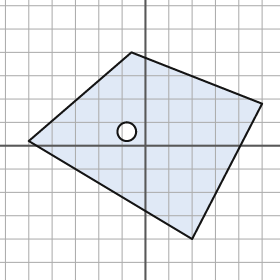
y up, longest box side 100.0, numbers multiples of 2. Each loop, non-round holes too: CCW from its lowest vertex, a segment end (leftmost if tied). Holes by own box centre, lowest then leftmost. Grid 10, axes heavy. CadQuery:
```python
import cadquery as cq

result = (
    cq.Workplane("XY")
    .moveTo(20.0, -40.0)
    .lineTo(50.0, 18.0)
    .lineTo(-6.0, 40.0)
    .lineTo(-50.0, 2.0)
    .close()
    .moveTo(-8.0, 6.0)
    .circle(4.0)
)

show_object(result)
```